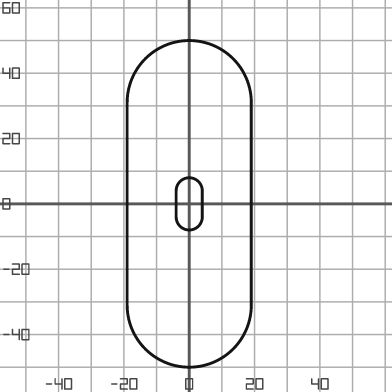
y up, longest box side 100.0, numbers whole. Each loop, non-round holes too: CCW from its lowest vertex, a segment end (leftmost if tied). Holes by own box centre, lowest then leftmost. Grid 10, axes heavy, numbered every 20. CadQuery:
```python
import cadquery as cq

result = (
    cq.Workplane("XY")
    .moveTo(-19.0, -31.0)
    .threePointArc((0.0, -50.0), (19.0, -31.0))
    .lineTo(19.0, 31.0)
    .threePointArc((0.0, 50.0), (-19.0, 31.0))
    .close()
    .moveTo(-4.0, -4.0)
    .threePointArc((0.0, -8.0), (4.0, -4.0))
    .lineTo(4.0, 4.0)
    .threePointArc((0.0, 8.0), (-4.0, 4.0))
    .close()
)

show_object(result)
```